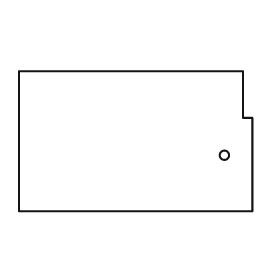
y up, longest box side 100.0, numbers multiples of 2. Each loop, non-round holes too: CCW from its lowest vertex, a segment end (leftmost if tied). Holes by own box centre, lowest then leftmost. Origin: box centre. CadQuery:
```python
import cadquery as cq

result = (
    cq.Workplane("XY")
    .moveTo(-50.0, -30.0)
    .lineTo(50.0, -30.0)
    .lineTo(50.0, 10.0)
    .lineTo(46.0, 10.0)
    .lineTo(46.0, 30.0)
    .lineTo(-50.0, 30.0)
    .close()
    .moveTo(38.0, -6.0)
    .circle(2.0)
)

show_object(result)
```